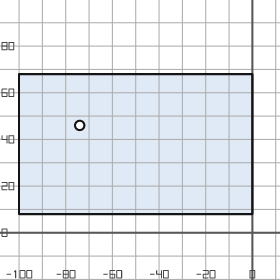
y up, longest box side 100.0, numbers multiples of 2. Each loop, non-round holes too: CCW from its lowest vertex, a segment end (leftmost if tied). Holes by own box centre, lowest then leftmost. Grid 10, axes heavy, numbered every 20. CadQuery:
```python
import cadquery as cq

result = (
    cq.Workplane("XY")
    .moveTo(-100.0, 8.0)
    .lineTo(0.0, 8.0)
    .lineTo(0.0, 68.0)
    .lineTo(-100.0, 68.0)
    .close()
    .moveTo(-74.0, 46.0)
    .circle(2.0)
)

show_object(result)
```